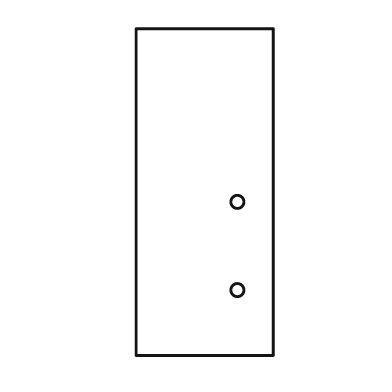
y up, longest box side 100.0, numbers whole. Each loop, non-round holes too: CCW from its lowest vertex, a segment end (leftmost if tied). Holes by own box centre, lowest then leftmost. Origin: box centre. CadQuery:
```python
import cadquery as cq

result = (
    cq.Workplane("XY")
    .moveTo(-21.0, -50.0)
    .lineTo(21.0, -50.0)
    .lineTo(21.0, 50.0)
    .lineTo(-21.0, 50.0)
    .close()
    .moveTo(10.0, -30.0)
    .circle(2.0)
    .moveTo(10.0, -3.0)
    .circle(2.0)
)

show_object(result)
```